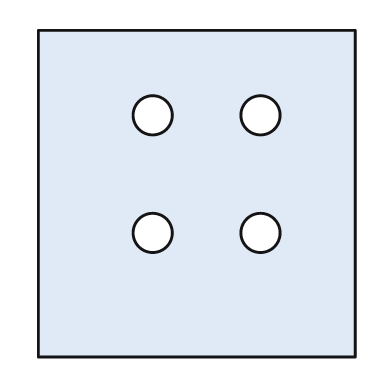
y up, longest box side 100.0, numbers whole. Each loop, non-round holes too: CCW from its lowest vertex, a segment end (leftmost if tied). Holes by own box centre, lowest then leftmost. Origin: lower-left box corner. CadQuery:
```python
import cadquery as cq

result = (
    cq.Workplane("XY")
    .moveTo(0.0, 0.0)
    .lineTo(97.0, 0.0)
    .lineTo(97.0, 100.0)
    .lineTo(0.0, 100.0)
    .close()
    .moveTo(35.0, 38.0)
    .circle(6.0)
    .moveTo(68.0, 38.0)
    .circle(6.0)
    .moveTo(35.0, 74.0)
    .circle(6.0)
    .moveTo(68.0, 74.0)
    .circle(6.0)
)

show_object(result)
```